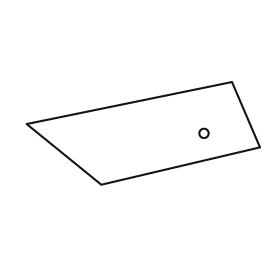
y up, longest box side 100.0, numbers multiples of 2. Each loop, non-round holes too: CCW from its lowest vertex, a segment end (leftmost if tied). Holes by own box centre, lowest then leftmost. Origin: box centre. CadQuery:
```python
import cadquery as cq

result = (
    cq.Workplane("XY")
    .moveTo(-18.0, -22.0)
    .lineTo(50.0, -6.0)
    .lineTo(38.0, 22.0)
    .lineTo(-50.0, 4.0)
    .close()
    .moveTo(26.0, 0.0)
    .circle(2.0)
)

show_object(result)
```